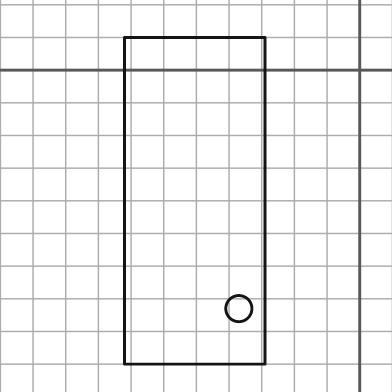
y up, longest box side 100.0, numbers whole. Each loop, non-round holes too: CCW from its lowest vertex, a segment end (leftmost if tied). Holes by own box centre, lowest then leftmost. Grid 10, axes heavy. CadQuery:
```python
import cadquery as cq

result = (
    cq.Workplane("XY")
    .moveTo(-72.0, -90.0)
    .lineTo(-29.0, -90.0)
    .lineTo(-29.0, 10.0)
    .lineTo(-72.0, 10.0)
    .close()
    .moveTo(-37.0, -73.0)
    .circle(4.0)
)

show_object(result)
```